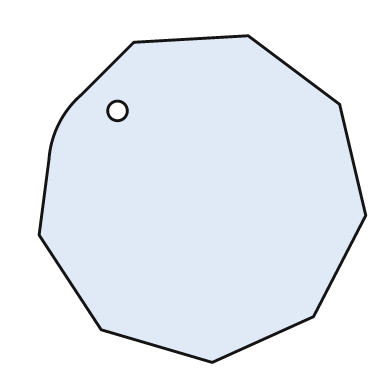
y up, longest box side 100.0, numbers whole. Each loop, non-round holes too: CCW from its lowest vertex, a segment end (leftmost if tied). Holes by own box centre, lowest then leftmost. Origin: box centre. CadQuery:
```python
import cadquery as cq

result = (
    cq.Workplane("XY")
    .moveTo(3.0, -50.0)
    .lineTo(34.0, -36.0)
    .lineTo(50.0, -5.0)
    .lineTo(42.0, 29.0)
    .lineTo(14.0, 50.0)
    .lineTo(-21.0, 48.0)
    .lineTo(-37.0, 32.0)
    .threePointArc((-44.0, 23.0), (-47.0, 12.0))
    .lineTo(-50.0, -11.0)
    .lineTo(-31.0, -40.0)
    .close()
    .moveTo(-26.0, 27.0)
    .circle(3.0)
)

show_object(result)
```